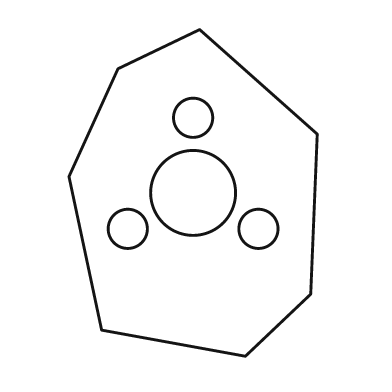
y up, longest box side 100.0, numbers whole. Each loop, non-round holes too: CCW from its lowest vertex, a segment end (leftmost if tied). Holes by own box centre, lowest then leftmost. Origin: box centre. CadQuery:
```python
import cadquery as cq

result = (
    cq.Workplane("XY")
    .moveTo(16.0, -50.0)
    .lineTo(36.0, -31.0)
    .lineTo(38.0, 18.0)
    .lineTo(2.0, 50.0)
    .lineTo(-23.0, 38.0)
    .lineTo(-38.0, 5.0)
    .lineTo(-28.0, -42.0)
    .close()
    .moveTo(-20.0, -11.0)
    .circle(6.0)
    .moveTo(20.0, -11.0)
    .circle(6.0)
    .moveTo(0.0, 0.0)
    .circle(13.0)
    .moveTo(0.0, 23.0)
    .circle(6.0)
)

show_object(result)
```